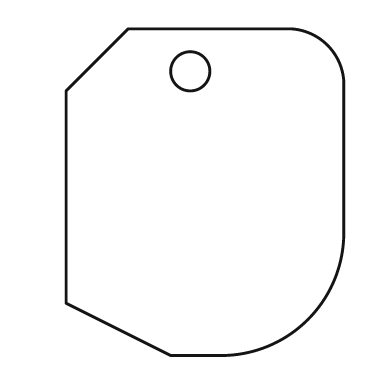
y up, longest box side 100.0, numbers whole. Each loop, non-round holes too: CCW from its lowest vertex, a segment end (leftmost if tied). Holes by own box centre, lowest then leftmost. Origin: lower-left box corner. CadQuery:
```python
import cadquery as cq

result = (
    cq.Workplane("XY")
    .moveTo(32.0, 0.0)
    .lineTo(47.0, 0.0)
    .threePointArc((74.0, 11.0), (85.0, 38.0))
    .lineTo(85.0, 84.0)
    .threePointArc((80.0, 95.0), (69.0, 100.0))
    .lineTo(19.0, 100.0)
    .lineTo(0.0, 81.0)
    .lineTo(0.0, 16.0)
    .close()
    .moveTo(38.0, 87.0)
    .circle(6.0)
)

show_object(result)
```